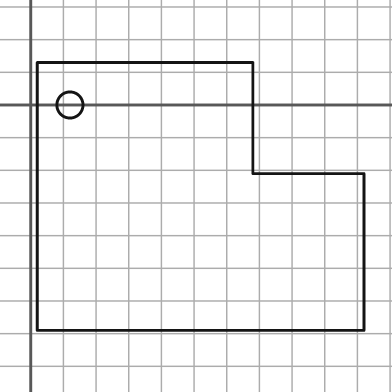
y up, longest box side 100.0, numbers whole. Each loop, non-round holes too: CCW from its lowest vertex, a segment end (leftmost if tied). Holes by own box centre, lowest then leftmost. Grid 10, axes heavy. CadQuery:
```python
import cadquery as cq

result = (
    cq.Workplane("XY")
    .moveTo(2.0, -69.0)
    .lineTo(102.0, -69.0)
    .lineTo(102.0, -21.0)
    .lineTo(68.0, -21.0)
    .lineTo(68.0, 13.0)
    .lineTo(2.0, 13.0)
    .close()
    .moveTo(12.0, 0.0)
    .circle(4.0)
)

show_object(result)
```